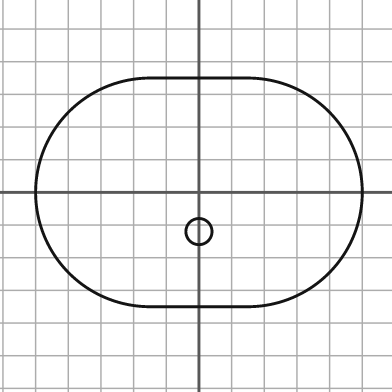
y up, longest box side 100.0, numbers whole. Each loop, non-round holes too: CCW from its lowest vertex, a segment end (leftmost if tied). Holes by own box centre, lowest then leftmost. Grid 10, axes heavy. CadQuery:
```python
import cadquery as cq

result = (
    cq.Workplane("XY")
    .moveTo(-15.0, -35.0)
    .lineTo(15.0, -35.0)
    .threePointArc((50.0, 0.0), (15.0, 35.0))
    .lineTo(-15.0, 35.0)
    .threePointArc((-50.0, 0.0), (-15.0, -35.0))
    .close()
    .moveTo(0.0, -12.0)
    .circle(4.0)
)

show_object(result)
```